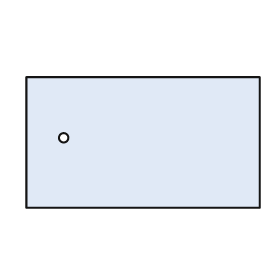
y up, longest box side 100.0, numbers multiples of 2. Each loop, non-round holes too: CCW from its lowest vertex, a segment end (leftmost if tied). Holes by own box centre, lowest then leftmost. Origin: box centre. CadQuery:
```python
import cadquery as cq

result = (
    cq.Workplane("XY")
    .moveTo(-50.0, -28.0)
    .lineTo(50.0, -28.0)
    .lineTo(50.0, 28.0)
    .lineTo(-50.0, 28.0)
    .close()
    .moveTo(-34.0, 2.0)
    .circle(2.0)
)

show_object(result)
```